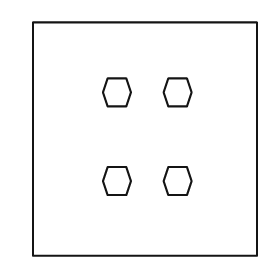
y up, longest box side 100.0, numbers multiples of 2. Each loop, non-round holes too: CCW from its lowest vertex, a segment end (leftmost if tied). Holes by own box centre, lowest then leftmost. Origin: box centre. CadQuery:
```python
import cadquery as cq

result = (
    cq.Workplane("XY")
    .moveTo(-48.0, -50.0)
    .lineTo(48.0, -50.0)
    .lineTo(48.0, 50.0)
    .lineTo(-48.0, 50.0)
    .close()
    .moveTo(-16.0, -24.0)
    .lineTo(-8.0, -24.0)
    .lineTo(-6.0, -18.0)
    .lineTo(-8.0, -12.0)
    .lineTo(-16.0, -12.0)
    .lineTo(-18.0, -18.0)
    .close()
    .moveTo(10.0, -24.0)
    .lineTo(18.0, -24.0)
    .lineTo(20.0, -18.0)
    .lineTo(18.0, -12.0)
    .lineTo(10.0, -12.0)
    .lineTo(8.0, -18.0)
    .close()
    .moveTo(-16.0, 14.0)
    .lineTo(-8.0, 14.0)
    .lineTo(-6.0, 20.0)
    .lineTo(-8.0, 26.0)
    .lineTo(-16.0, 26.0)
    .lineTo(-18.0, 20.0)
    .close()
    .moveTo(10.0, 14.0)
    .lineTo(18.0, 14.0)
    .lineTo(20.0, 20.0)
    .lineTo(18.0, 26.0)
    .lineTo(10.0, 26.0)
    .lineTo(8.0, 20.0)
    .close()
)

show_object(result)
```